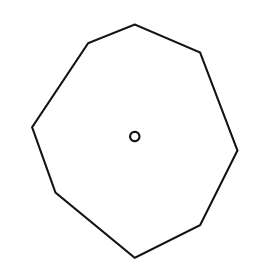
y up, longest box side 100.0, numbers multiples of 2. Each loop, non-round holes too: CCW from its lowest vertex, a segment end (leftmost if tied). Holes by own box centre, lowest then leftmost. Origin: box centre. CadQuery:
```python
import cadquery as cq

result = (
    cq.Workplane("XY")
    .moveTo(0.0, -50.0)
    .lineTo(28.0, -36.0)
    .lineTo(44.0, -4.0)
    .lineTo(28.0, 38.0)
    .lineTo(0.0, 50.0)
    .lineTo(-20.0, 42.0)
    .lineTo(-44.0, 6.0)
    .lineTo(-34.0, -22.0)
    .close()
    .moveTo(0.0, 2.0)
    .circle(2.0)
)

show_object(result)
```